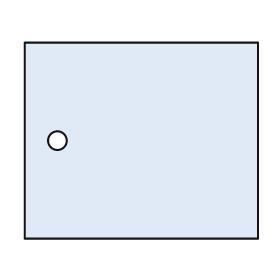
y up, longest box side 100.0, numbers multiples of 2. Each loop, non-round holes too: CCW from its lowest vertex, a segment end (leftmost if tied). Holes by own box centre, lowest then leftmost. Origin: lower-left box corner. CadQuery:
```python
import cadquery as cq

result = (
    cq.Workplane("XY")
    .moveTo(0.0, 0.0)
    .lineTo(100.0, 0.0)
    .lineTo(100.0, 84.0)
    .lineTo(0.0, 84.0)
    .close()
    .moveTo(14.0, 42.0)
    .circle(4.0)
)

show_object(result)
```